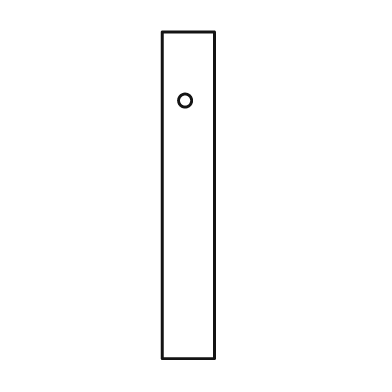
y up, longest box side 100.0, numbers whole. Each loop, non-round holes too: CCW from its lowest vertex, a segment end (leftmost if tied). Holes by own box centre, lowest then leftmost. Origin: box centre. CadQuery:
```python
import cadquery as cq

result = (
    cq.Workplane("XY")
    .moveTo(-8.0, -50.0)
    .lineTo(8.0, -50.0)
    .lineTo(8.0, 50.0)
    .lineTo(-8.0, 50.0)
    .close()
    .moveTo(-1.0, 29.0)
    .circle(2.0)
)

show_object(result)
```